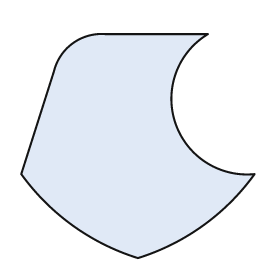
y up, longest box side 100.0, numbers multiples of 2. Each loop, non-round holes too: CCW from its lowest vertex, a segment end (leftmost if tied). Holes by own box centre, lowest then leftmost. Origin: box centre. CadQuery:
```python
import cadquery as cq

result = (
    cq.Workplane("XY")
    .moveTo(0.0, -48.0)
    .threePointArc((28.0, -34.0), (50.0, -12.0))
    .threePointArc((16.0, 10.0), (30.0, 48.0))
    .lineTo(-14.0, 48.0)
    .threePointArc((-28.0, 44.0), (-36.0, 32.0))
    .lineTo(-50.0, -12.0)
    .threePointArc((-28.0, -34.0), (0.0, -48.0))
    .close()
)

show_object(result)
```